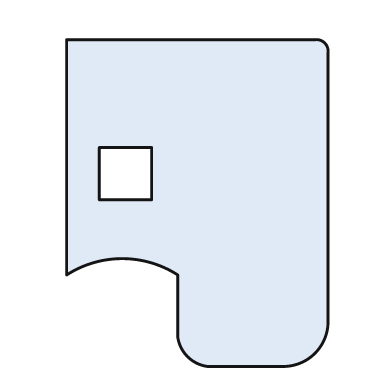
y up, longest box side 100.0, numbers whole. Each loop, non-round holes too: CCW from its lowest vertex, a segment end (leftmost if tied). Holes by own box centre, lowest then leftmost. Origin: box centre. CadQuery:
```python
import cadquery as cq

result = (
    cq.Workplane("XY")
    .moveTo(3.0, -50.0)
    .lineTo(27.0, -50.0)
    .threePointArc((36.0, -46.0), (40.0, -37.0))
    .lineTo(40.0, 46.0)
    .threePointArc((39.0, 49.0), (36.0, 50.0))
    .lineTo(-40.0, 50.0)
    .lineTo(-40.0, -22.0)
    .threePointArc((-23.0, -17.0), (-6.0, -22.0))
    .lineTo(-6.0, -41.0)
    .threePointArc((-3.0, -47.0), (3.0, -50.0))
    .close()
    .moveTo(-30.0, 1.0)
    .lineTo(-14.0, 1.0)
    .lineTo(-14.0, 17.0)
    .lineTo(-30.0, 17.0)
    .close()
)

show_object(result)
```